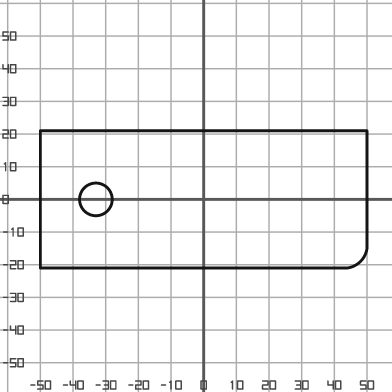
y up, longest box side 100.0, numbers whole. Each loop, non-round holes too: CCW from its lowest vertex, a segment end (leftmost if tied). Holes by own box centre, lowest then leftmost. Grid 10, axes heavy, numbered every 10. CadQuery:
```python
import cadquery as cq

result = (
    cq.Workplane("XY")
    .moveTo(-50.0, -21.0)
    .lineTo(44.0, -21.0)
    .threePointArc((48.0, -19.0), (50.0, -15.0))
    .lineTo(50.0, 21.0)
    .lineTo(-50.0, 21.0)
    .close()
    .moveTo(-33.0, 0.0)
    .circle(5.0)
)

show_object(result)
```